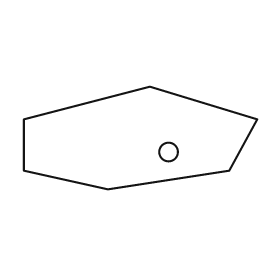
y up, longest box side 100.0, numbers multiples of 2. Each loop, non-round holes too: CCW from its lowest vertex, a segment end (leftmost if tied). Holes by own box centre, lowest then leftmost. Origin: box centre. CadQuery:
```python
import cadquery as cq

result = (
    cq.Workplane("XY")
    .moveTo(-14.0, -22.0)
    .lineTo(38.0, -14.0)
    .lineTo(50.0, 8.0)
    .lineTo(4.0, 22.0)
    .lineTo(-50.0, 8.0)
    .lineTo(-50.0, -14.0)
    .close()
    .moveTo(12.0, -6.0)
    .circle(4.0)
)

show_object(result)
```